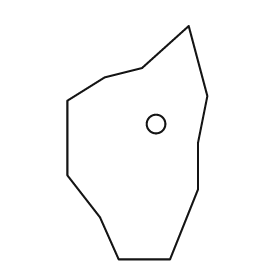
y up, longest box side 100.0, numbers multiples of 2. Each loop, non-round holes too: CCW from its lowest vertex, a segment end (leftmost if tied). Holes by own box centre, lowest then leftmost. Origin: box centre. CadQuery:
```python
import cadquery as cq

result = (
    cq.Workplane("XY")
    .moveTo(-8.0, -50.0)
    .lineTo(14.0, -50.0)
    .lineTo(26.0, -20.0)
    .lineTo(26.0, 0.0)
    .lineTo(30.0, 20.0)
    .lineTo(22.0, 50.0)
    .lineTo(2.0, 32.0)
    .lineTo(-14.0, 28.0)
    .lineTo(-30.0, 18.0)
    .lineTo(-30.0, -14.0)
    .lineTo(-16.0, -32.0)
    .close()
    .moveTo(8.0, 8.0)
    .circle(4.0)
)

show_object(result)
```